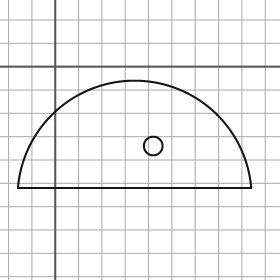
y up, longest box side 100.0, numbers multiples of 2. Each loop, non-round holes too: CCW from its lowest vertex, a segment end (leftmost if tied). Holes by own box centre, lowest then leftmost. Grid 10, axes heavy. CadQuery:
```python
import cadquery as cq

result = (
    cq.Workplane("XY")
    .moveTo(-16.0, -52.0)
    .lineTo(84.0, -52.0)
    .threePointArc((34.0, -6.0), (-16.0, -52.0))
    .close()
    .moveTo(42.0, -34.0)
    .circle(4.0)
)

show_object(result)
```